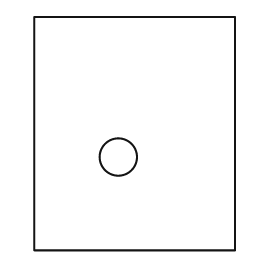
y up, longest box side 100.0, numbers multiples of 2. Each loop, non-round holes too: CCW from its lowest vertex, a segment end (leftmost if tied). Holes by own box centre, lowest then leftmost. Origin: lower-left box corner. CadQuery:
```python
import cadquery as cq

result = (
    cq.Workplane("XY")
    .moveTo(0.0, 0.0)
    .lineTo(86.0, 0.0)
    .lineTo(86.0, 100.0)
    .lineTo(0.0, 100.0)
    .close()
    .moveTo(36.0, 40.0)
    .circle(8.0)
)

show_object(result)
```